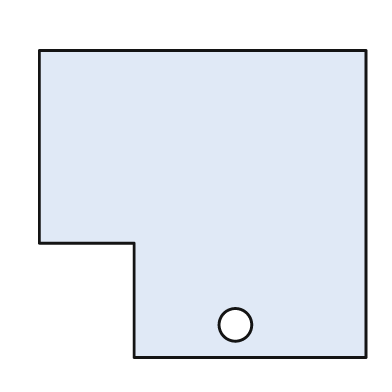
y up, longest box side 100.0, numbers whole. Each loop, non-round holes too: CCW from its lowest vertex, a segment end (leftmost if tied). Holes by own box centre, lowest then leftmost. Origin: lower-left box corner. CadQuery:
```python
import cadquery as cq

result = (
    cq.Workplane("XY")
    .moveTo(29.0, 0.0)
    .lineTo(100.0, 0.0)
    .lineTo(100.0, 94.0)
    .lineTo(0.0, 94.0)
    .lineTo(0.0, 35.0)
    .lineTo(29.0, 35.0)
    .close()
    .moveTo(60.0, 10.0)
    .circle(5.0)
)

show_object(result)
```